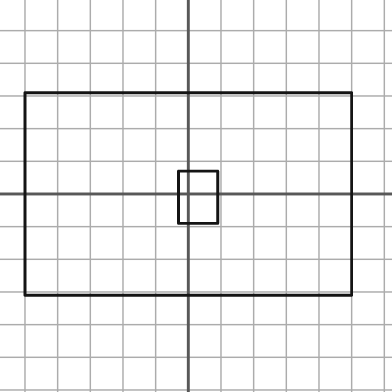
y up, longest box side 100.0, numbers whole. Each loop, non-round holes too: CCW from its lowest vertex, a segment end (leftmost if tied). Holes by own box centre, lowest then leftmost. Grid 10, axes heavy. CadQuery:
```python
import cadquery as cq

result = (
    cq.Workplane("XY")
    .moveTo(-50.0, -31.0)
    .lineTo(50.0, -31.0)
    .lineTo(50.0, 31.0)
    .lineTo(-50.0, 31.0)
    .close()
    .moveTo(-3.0, -9.0)
    .lineTo(9.0, -9.0)
    .lineTo(9.0, 7.0)
    .lineTo(-3.0, 7.0)
    .close()
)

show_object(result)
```